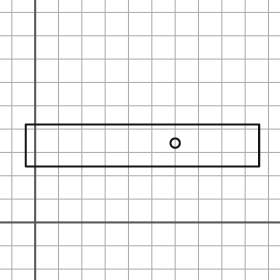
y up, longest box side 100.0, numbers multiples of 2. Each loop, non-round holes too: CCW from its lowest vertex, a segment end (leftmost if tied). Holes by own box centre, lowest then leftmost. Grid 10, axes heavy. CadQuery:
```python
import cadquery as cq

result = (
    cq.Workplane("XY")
    .moveTo(-4.0, 24.0)
    .lineTo(96.0, 24.0)
    .lineTo(96.0, 42.0)
    .lineTo(-4.0, 42.0)
    .close()
    .moveTo(60.0, 34.0)
    .circle(2.0)
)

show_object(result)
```